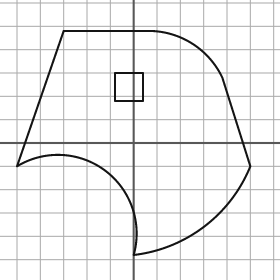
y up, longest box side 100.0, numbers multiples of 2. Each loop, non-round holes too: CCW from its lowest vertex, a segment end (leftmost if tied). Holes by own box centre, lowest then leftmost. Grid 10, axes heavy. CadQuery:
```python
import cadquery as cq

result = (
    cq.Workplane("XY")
    .moveTo(0.0, -48.0)
    .threePointArc((30.0, -36.0), (50.0, -10.0))
    .lineTo(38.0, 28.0)
    .threePointArc((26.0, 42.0), (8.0, 48.0))
    .lineTo(-30.0, 48.0)
    .lineTo(-50.0, -10.0)
    .threePointArc((-12.0, -12.0), (0.0, -48.0))
    .close()
    .moveTo(-8.0, 18.0)
    .lineTo(4.0, 18.0)
    .lineTo(4.0, 30.0)
    .lineTo(-8.0, 30.0)
    .close()
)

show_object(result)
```